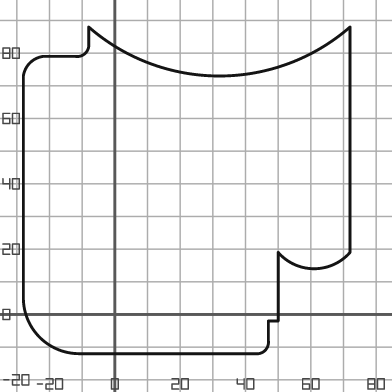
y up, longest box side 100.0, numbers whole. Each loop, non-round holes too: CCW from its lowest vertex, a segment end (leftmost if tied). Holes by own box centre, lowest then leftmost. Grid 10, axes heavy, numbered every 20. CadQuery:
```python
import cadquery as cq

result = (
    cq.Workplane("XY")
    .moveTo(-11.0, -12.0)
    .lineTo(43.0, -12.0)
    .threePointArc((46.0, -11.0), (47.0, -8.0))
    .lineTo(47.0, -2.0)
    .lineTo(50.0, -2.0)
    .lineTo(50.0, 19.0)
    .threePointArc((61.0, 14.0), (72.0, 19.0))
    .lineTo(72.0, 88.0)
    .threePointArc((32.0, 73.0), (-8.0, 88.0))
    .lineTo(-8.0, 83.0)
    .threePointArc((-9.0, 80.0), (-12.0, 79.0))
    .lineTo(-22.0, 79.0)
    .threePointArc((-26.0, 77.0), (-28.0, 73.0))
    .lineTo(-28.0, 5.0)
    .threePointArc((-23.0, -7.0), (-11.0, -12.0))
    .close()
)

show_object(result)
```